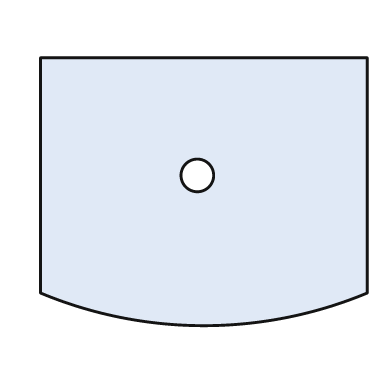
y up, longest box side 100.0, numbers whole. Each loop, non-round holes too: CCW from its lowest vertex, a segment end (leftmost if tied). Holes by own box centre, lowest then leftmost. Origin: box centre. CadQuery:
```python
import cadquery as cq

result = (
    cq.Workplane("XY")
    .moveTo(-50.0, -31.0)
    .threePointArc((0.0, -41.0), (50.0, -31.0))
    .lineTo(50.0, 41.0)
    .lineTo(-50.0, 41.0)
    .close()
    .moveTo(-2.0, 5.0)
    .circle(5.0)
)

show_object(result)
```